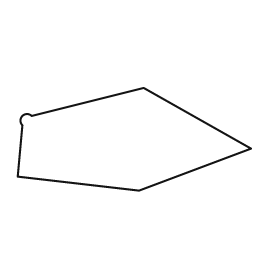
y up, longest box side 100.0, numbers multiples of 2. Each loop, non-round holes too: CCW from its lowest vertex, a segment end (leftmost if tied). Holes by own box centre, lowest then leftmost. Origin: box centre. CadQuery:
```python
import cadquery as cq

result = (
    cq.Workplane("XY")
    .moveTo(2.0, -22.0)
    .lineTo(50.0, -4.0)
    .lineTo(4.0, 22.0)
    .lineTo(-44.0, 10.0)
    .threePointArc((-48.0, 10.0), (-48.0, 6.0))
    .lineTo(-50.0, -16.0)
    .close()
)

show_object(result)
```